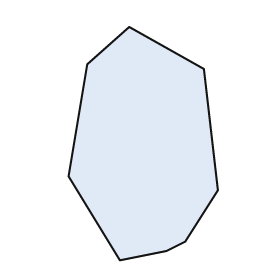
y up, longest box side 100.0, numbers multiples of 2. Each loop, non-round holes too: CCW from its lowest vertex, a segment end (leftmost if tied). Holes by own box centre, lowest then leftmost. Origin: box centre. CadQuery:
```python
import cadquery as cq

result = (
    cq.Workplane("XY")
    .moveTo(-10.0, -50.0)
    .lineTo(10.0, -46.0)
    .lineTo(18.0, -42.0)
    .lineTo(32.0, -20.0)
    .lineTo(26.0, 32.0)
    .lineTo(-6.0, 50.0)
    .lineTo(-24.0, 34.0)
    .lineTo(-32.0, -14.0)
    .close()
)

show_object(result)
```